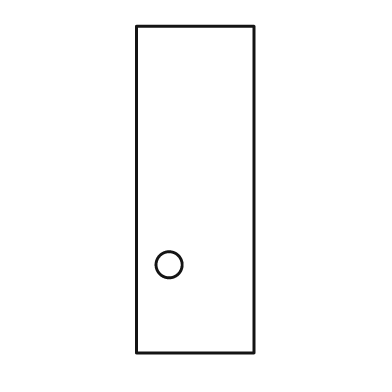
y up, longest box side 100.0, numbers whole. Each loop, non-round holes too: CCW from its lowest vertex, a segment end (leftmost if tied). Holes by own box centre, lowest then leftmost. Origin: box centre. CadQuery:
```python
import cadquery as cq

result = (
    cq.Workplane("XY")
    .moveTo(-18.0, -50.0)
    .lineTo(18.0, -50.0)
    .lineTo(18.0, 50.0)
    .lineTo(-18.0, 50.0)
    .close()
    .moveTo(-8.0, -23.0)
    .circle(4.0)
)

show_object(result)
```